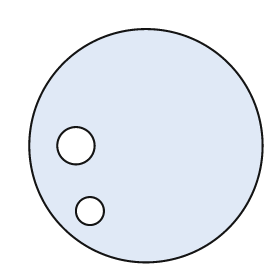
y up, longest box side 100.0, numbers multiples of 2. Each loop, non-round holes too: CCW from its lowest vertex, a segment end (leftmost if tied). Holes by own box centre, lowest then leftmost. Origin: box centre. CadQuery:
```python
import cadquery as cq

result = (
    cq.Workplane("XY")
    .moveTo(0.0, 0.0)
    .circle(50.0)
    .moveTo(-24.0, -28.0)
    .circle(6.0)
    .moveTo(-30.0, 0.0)
    .circle(8.0)
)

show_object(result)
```